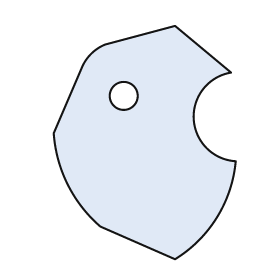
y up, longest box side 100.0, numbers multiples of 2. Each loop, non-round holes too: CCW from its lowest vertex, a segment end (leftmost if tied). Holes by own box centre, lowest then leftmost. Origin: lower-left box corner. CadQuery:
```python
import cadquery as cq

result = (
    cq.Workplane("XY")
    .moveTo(52.0, 0.0)
    .threePointArc((70.0, 18.0), (78.0, 42.0))
    .threePointArc((60.0, 60.0), (76.0, 80.0))
    .lineTo(52.0, 100.0)
    .lineTo(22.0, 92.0)
    .threePointArc((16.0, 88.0), (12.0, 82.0))
    .lineTo(0.0, 54.0)
    .threePointArc((6.0, 32.0), (20.0, 14.0))
    .close()
    .moveTo(30.0, 70.0)
    .circle(6.0)
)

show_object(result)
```